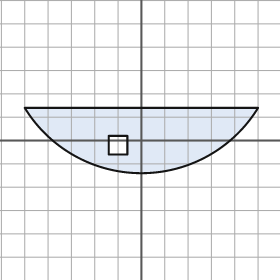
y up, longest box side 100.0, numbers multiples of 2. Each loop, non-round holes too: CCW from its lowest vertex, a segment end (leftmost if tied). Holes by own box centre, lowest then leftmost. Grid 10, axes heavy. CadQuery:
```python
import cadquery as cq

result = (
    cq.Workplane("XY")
    .moveTo(-50.0, 14.0)
    .threePointArc((0.0, -14.0), (50.0, 14.0))
    .close()
    .moveTo(-14.0, -6.0)
    .lineTo(-6.0, -6.0)
    .lineTo(-6.0, 2.0)
    .lineTo(-14.0, 2.0)
    .close()
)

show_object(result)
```